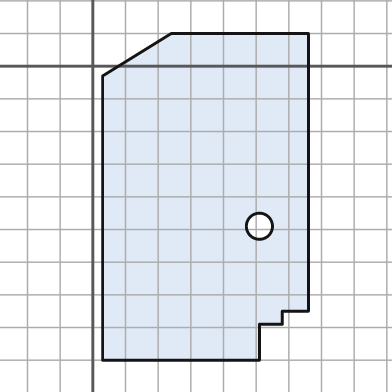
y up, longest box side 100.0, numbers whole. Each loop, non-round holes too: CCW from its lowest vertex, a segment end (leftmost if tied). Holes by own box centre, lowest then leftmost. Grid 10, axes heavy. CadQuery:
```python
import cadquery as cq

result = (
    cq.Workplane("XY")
    .moveTo(3.0, -90.0)
    .lineTo(51.0, -90.0)
    .lineTo(51.0, -79.0)
    .lineTo(58.0, -79.0)
    .lineTo(58.0, -75.0)
    .lineTo(66.0, -75.0)
    .lineTo(66.0, 10.0)
    .lineTo(24.0, 10.0)
    .lineTo(3.0, -3.0)
    .close()
    .moveTo(51.0, -49.0)
    .circle(4.0)
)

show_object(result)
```